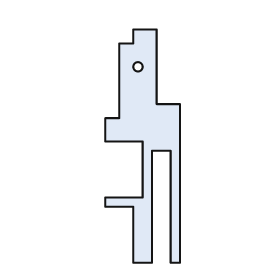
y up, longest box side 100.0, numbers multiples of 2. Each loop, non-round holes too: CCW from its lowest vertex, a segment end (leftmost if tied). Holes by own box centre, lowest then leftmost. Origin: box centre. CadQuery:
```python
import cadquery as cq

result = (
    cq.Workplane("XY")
    .moveTo(-4.0, -50.0)
    .lineTo(4.0, -50.0)
    .lineTo(4.0, -2.0)
    .lineTo(12.0, -2.0)
    .lineTo(12.0, -50.0)
    .lineTo(16.0, -50.0)
    .lineTo(16.0, 18.0)
    .lineTo(6.0, 18.0)
    .lineTo(6.0, 50.0)
    .lineTo(-4.0, 50.0)
    .lineTo(-4.0, 44.0)
    .lineTo(-10.0, 44.0)
    .lineTo(-10.0, 12.0)
    .lineTo(-16.0, 12.0)
    .lineTo(-16.0, 2.0)
    .lineTo(0.0, 2.0)
    .lineTo(0.0, -22.0)
    .lineTo(-16.0, -22.0)
    .lineTo(-16.0, -26.0)
    .lineTo(-4.0, -26.0)
    .close()
    .moveTo(-2.0, 34.0)
    .circle(2.0)
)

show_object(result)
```